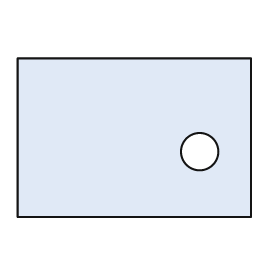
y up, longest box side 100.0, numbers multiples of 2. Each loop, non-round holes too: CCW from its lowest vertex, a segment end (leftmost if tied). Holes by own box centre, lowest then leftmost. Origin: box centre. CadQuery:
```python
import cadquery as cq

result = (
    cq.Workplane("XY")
    .moveTo(-50.0, -34.0)
    .lineTo(50.0, -34.0)
    .lineTo(50.0, 34.0)
    .lineTo(-50.0, 34.0)
    .close()
    .moveTo(28.0, -6.0)
    .circle(8.0)
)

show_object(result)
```